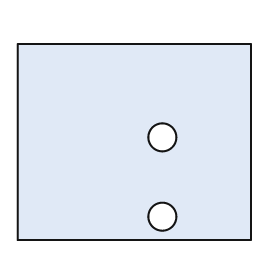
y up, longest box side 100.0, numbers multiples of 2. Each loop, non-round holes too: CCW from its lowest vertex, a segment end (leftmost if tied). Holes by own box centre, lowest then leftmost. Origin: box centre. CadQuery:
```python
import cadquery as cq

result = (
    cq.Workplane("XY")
    .moveTo(-50.0, -42.0)
    .lineTo(50.0, -42.0)
    .lineTo(50.0, 42.0)
    .lineTo(-50.0, 42.0)
    .close()
    .moveTo(12.0, -32.0)
    .circle(6.0)
    .moveTo(12.0, 2.0)
    .circle(6.0)
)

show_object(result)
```